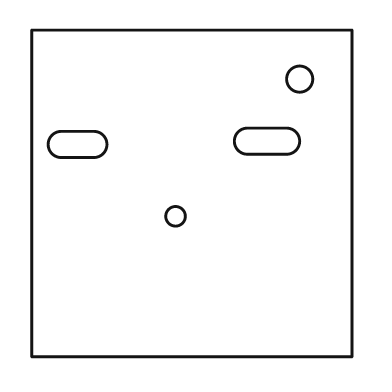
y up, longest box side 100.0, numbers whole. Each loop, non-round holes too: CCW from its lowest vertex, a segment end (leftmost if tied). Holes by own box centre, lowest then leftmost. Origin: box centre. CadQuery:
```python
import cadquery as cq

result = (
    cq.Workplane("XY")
    .moveTo(-49.0, -50.0)
    .lineTo(49.0, -50.0)
    .lineTo(49.0, 50.0)
    .lineTo(-49.0, 50.0)
    .close()
    .moveTo(-5.0, -7.0)
    .circle(3.0)
    .moveTo(-40.0, 11.0)
    .lineTo(-30.0, 11.0)
    .threePointArc((-26.0, 15.0), (-30.0, 19.0))
    .lineTo(-40.0, 19.0)
    .threePointArc((-44.0, 15.0), (-40.0, 11.0))
    .close()
    .moveTo(17.0, 12.0)
    .lineTo(29.0, 12.0)
    .threePointArc((33.0, 16.0), (29.0, 20.0))
    .lineTo(17.0, 20.0)
    .threePointArc((13.0, 16.0), (17.0, 12.0))
    .close()
    .moveTo(33.0, 35.0)
    .circle(4.0)
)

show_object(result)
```